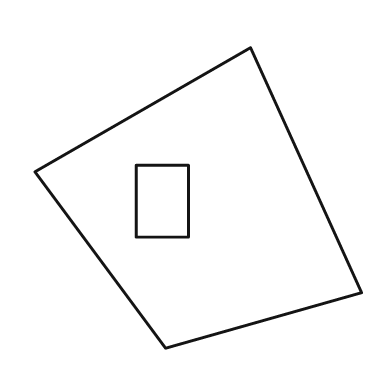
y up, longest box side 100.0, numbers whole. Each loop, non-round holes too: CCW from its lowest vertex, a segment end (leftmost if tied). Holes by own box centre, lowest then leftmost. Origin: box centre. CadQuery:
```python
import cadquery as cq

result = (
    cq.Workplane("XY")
    .moveTo(-10.0, -46.0)
    .lineTo(50.0, -29.0)
    .lineTo(16.0, 46.0)
    .lineTo(-50.0, 8.0)
    .close()
    .moveTo(-19.0, -12.0)
    .lineTo(-3.0, -12.0)
    .lineTo(-3.0, 10.0)
    .lineTo(-19.0, 10.0)
    .close()
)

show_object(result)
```